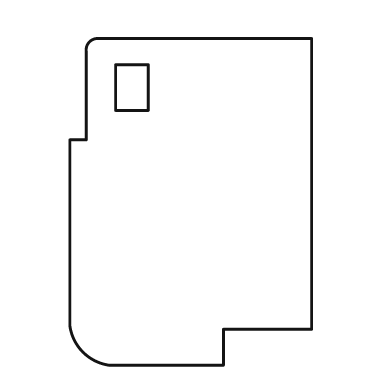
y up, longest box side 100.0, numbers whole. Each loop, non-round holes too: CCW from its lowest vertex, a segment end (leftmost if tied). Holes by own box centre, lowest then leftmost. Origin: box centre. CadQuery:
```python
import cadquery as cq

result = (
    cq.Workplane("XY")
    .moveTo(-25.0, -50.0)
    .lineTo(10.0, -50.0)
    .lineTo(10.0, -39.0)
    .lineTo(37.0, -39.0)
    .lineTo(37.0, 50.0)
    .lineTo(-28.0, 50.0)
    .threePointArc((-31.0, 49.0), (-32.0, 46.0))
    .lineTo(-32.0, 19.0)
    .lineTo(-37.0, 19.0)
    .lineTo(-37.0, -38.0)
    .threePointArc((-33.0, -46.0), (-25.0, -50.0))
    .close()
    .moveTo(-23.0, 28.0)
    .lineTo(-13.0, 28.0)
    .lineTo(-13.0, 42.0)
    .lineTo(-23.0, 42.0)
    .close()
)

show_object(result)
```